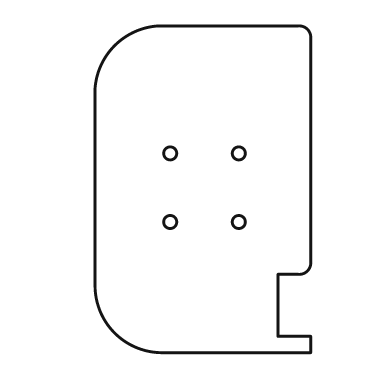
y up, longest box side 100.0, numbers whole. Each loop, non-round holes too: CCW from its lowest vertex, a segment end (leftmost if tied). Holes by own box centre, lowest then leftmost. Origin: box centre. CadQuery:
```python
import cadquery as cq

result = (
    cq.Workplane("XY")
    .moveTo(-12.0, -50.0)
    .lineTo(33.0, -50.0)
    .lineTo(33.0, -45.0)
    .lineTo(23.0, -45.0)
    .lineTo(23.0, -26.0)
    .lineTo(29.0, -26.0)
    .threePointArc((32.0, -25.0), (33.0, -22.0))
    .lineTo(33.0, 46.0)
    .threePointArc((32.0, 49.0), (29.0, 50.0))
    .lineTo(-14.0, 50.0)
    .threePointArc((-27.0, 44.0), (-33.0, 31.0))
    .lineTo(-33.0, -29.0)
    .threePointArc((-27.0, -44.0), (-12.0, -50.0))
    .close()
    .moveTo(-10.0, -10.0)
    .circle(2.0)
    .moveTo(11.0, -10.0)
    .circle(2.0)
    .moveTo(-10.0, 11.0)
    .circle(2.0)
    .moveTo(11.0, 11.0)
    .circle(2.0)
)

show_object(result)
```